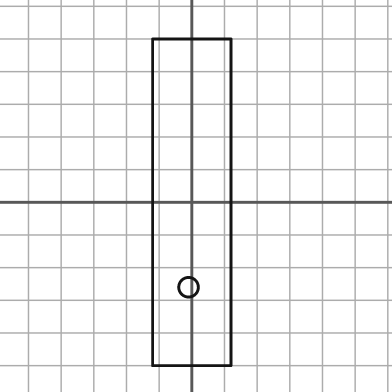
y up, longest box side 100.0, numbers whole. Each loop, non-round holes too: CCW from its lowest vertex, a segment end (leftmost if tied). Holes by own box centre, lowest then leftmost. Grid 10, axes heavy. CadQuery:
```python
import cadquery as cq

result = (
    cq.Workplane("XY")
    .moveTo(-12.0, -50.0)
    .lineTo(12.0, -50.0)
    .lineTo(12.0, 50.0)
    .lineTo(-12.0, 50.0)
    .close()
    .moveTo(-1.0, -26.0)
    .circle(3.0)
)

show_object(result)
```